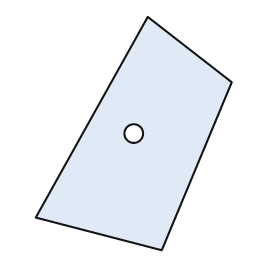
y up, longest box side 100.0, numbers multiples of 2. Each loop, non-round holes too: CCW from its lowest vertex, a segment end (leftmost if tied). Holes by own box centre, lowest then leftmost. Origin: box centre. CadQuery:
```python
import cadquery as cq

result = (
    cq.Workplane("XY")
    .moveTo(12.0, -50.0)
    .lineTo(42.0, 22.0)
    .lineTo(6.0, 50.0)
    .lineTo(-42.0, -36.0)
    .close()
    .moveTo(0.0, 0.0)
    .circle(4.0)
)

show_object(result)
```